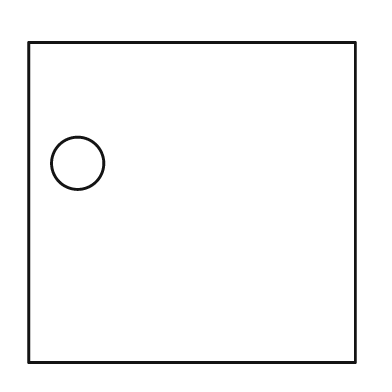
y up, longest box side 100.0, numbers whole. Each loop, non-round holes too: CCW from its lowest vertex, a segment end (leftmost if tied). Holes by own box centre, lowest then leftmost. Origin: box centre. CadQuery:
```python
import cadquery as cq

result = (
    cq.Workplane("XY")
    .moveTo(-50.0, -49.0)
    .lineTo(50.0, -49.0)
    .lineTo(50.0, 49.0)
    .lineTo(-50.0, 49.0)
    .close()
    .moveTo(-35.0, 12.0)
    .circle(8.0)
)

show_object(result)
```